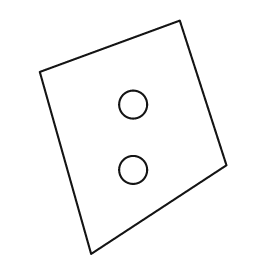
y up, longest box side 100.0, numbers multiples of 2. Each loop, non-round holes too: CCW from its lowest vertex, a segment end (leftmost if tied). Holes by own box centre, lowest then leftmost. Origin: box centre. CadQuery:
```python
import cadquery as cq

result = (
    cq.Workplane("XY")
    .moveTo(-18.0, -50.0)
    .lineTo(40.0, -12.0)
    .lineTo(20.0, 50.0)
    .lineTo(-40.0, 28.0)
    .close()
    .moveTo(0.0, -14.0)
    .circle(6.0)
    .moveTo(0.0, 14.0)
    .circle(6.0)
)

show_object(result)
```